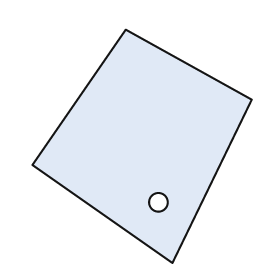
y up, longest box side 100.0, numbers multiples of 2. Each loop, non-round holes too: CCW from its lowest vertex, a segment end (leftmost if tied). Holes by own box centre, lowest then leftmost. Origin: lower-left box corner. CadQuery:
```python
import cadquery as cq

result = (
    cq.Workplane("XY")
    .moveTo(60.0, 0.0)
    .lineTo(94.0, 70.0)
    .lineTo(40.0, 100.0)
    .lineTo(0.0, 42.0)
    .close()
    .moveTo(54.0, 26.0)
    .circle(4.0)
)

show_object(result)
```